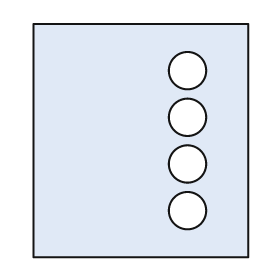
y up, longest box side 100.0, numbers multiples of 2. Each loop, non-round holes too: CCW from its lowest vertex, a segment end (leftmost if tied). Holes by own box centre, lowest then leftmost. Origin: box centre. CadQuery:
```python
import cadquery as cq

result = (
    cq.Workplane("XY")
    .moveTo(-46.0, -50.0)
    .lineTo(46.0, -50.0)
    .lineTo(46.0, 50.0)
    .lineTo(-46.0, 50.0)
    .close()
    .moveTo(20.0, -30.0)
    .circle(8.0)
    .moveTo(20.0, -10.0)
    .circle(8.0)
    .moveTo(20.0, 10.0)
    .circle(8.0)
    .moveTo(20.0, 30.0)
    .circle(8.0)
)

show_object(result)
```